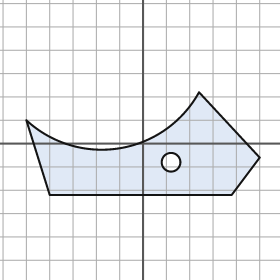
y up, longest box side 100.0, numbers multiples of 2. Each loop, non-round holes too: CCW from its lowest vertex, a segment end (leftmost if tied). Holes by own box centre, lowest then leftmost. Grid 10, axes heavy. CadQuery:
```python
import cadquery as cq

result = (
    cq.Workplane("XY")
    .moveTo(-40.0, -22.0)
    .lineTo(38.0, -22.0)
    .lineTo(50.0, -6.0)
    .lineTo(24.0, 22.0)
    .threePointArc((-10.0, -2.0), (-50.0, 10.0))
    .close()
    .moveTo(12.0, -8.0)
    .circle(4.0)
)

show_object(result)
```